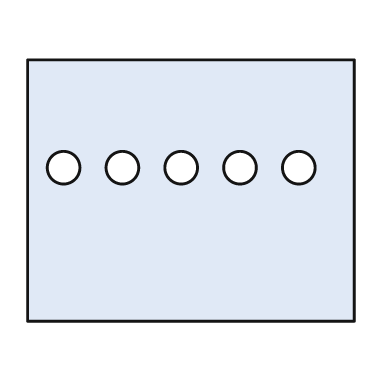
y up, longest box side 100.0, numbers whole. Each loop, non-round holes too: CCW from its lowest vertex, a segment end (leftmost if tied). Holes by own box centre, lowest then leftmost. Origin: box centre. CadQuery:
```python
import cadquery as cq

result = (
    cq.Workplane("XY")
    .moveTo(-50.0, -40.0)
    .lineTo(50.0, -40.0)
    .lineTo(50.0, 40.0)
    .lineTo(-50.0, 40.0)
    .close()
    .moveTo(-39.0, 7.0)
    .circle(5.0)
    .moveTo(-21.0, 7.0)
    .circle(5.0)
    .moveTo(-3.0, 7.0)
    .circle(5.0)
    .moveTo(15.0, 7.0)
    .circle(5.0)
    .moveTo(33.0, 7.0)
    .circle(5.0)
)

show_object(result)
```